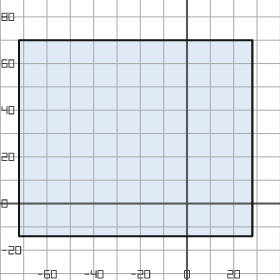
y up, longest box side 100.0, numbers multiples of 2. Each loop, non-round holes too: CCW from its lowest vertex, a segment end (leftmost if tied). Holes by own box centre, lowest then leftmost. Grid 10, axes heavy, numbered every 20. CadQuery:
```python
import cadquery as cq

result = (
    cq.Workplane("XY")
    .moveTo(-72.0, -14.0)
    .lineTo(28.0, -14.0)
    .lineTo(28.0, 70.0)
    .lineTo(-72.0, 70.0)
    .close()
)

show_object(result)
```